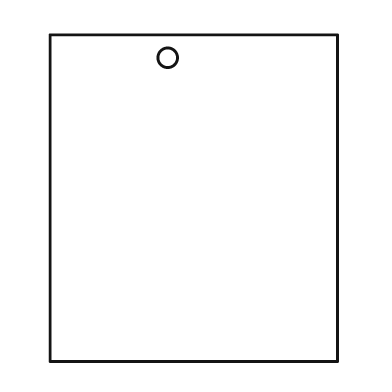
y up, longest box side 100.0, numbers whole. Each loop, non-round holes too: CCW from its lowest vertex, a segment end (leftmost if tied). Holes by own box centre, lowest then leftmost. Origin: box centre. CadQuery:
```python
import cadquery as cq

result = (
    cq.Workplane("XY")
    .moveTo(-44.0, -50.0)
    .lineTo(44.0, -50.0)
    .lineTo(44.0, 50.0)
    .lineTo(-44.0, 50.0)
    .close()
    .moveTo(-8.0, 43.0)
    .circle(3.0)
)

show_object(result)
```